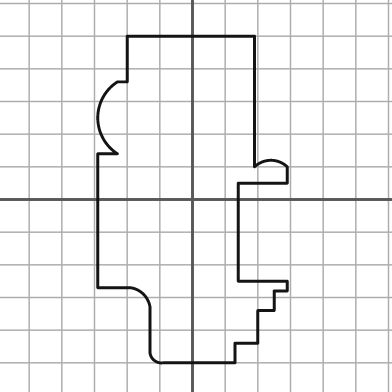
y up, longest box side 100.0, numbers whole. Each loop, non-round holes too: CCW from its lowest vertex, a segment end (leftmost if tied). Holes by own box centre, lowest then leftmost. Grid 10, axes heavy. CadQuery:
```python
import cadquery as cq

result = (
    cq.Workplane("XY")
    .moveTo(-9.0, -50.0)
    .lineTo(13.0, -50.0)
    .lineTo(13.0, -44.0)
    .lineTo(20.0, -44.0)
    .lineTo(20.0, -34.0)
    .lineTo(25.0, -34.0)
    .lineTo(25.0, -28.0)
    .lineTo(29.0, -28.0)
    .lineTo(29.0, -25.0)
    .lineTo(14.0, -25.0)
    .lineTo(14.0, 5.0)
    .lineTo(29.0, 5.0)
    .lineTo(29.0, 10.0)
    .threePointArc((24.0, 12.0), (19.0, 10.0))
    .lineTo(19.0, 50.0)
    .lineTo(-20.0, 50.0)
    .lineTo(-20.0, 36.0)
    .lineTo(-23.0, 36.0)
    .threePointArc((-29.0, 25.0), (-23.0, 14.0))
    .lineTo(-29.0, 14.0)
    .lineTo(-29.0, -27.0)
    .lineTo(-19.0, -27.0)
    .threePointArc((-15.0, -29.0), (-13.0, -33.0))
    .lineTo(-13.0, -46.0)
    .threePointArc((-12.0, -49.0), (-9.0, -50.0))
    .close()
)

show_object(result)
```